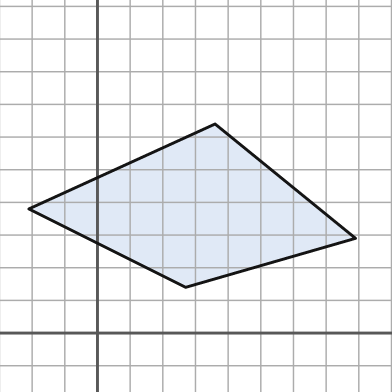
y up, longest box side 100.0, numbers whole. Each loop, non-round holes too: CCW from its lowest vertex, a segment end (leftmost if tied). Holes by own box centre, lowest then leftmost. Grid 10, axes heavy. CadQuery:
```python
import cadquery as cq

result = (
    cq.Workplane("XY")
    .moveTo(27.0, 14.0)
    .lineTo(79.0, 29.0)
    .lineTo(36.0, 64.0)
    .lineTo(-21.0, 38.0)
    .close()
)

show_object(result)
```